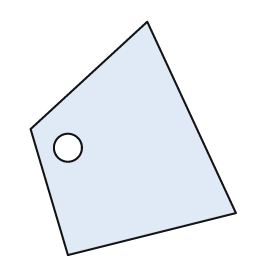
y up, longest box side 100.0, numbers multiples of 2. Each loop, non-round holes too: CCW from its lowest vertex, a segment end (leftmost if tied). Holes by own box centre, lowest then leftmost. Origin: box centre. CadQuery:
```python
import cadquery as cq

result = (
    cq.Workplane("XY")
    .moveTo(-28.0, -50.0)
    .lineTo(44.0, -32.0)
    .lineTo(6.0, 50.0)
    .lineTo(-44.0, 4.0)
    .close()
    .moveTo(-28.0, -4.0)
    .circle(6.0)
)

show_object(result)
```